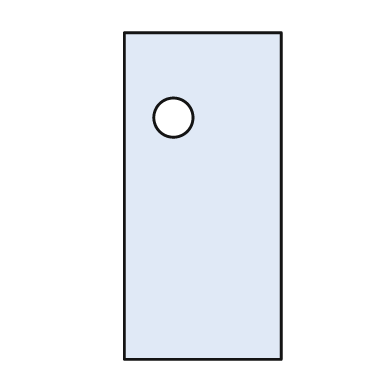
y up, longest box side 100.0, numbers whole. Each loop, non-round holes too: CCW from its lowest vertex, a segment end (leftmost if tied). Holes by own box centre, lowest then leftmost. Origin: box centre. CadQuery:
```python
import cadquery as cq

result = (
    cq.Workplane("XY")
    .moveTo(-24.0, -50.0)
    .lineTo(24.0, -50.0)
    .lineTo(24.0, 50.0)
    .lineTo(-24.0, 50.0)
    .close()
    .moveTo(-9.0, 24.0)
    .circle(6.0)
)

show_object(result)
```